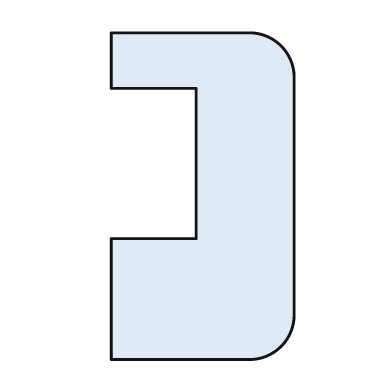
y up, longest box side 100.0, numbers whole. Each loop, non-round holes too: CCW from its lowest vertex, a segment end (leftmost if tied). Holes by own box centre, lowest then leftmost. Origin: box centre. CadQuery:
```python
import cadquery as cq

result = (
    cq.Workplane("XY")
    .moveTo(-28.0, -50.0)
    .lineTo(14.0, -50.0)
    .threePointArc((24.0, -46.0), (28.0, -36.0))
    .lineTo(28.0, 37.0)
    .threePointArc((24.0, 46.0), (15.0, 50.0))
    .lineTo(-28.0, 50.0)
    .lineTo(-28.0, 33.0)
    .lineTo(-2.0, 33.0)
    .lineTo(-2.0, -13.0)
    .lineTo(-28.0, -13.0)
    .close()
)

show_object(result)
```